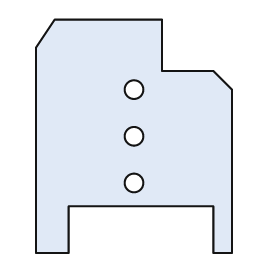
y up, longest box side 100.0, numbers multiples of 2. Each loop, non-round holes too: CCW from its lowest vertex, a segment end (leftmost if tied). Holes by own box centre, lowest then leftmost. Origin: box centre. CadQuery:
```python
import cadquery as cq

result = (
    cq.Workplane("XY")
    .moveTo(-42.0, -50.0)
    .lineTo(-28.0, -50.0)
    .lineTo(-28.0, -30.0)
    .lineTo(34.0, -30.0)
    .lineTo(34.0, -50.0)
    .lineTo(42.0, -50.0)
    .lineTo(42.0, 20.0)
    .lineTo(34.0, 28.0)
    .lineTo(12.0, 28.0)
    .lineTo(12.0, 50.0)
    .lineTo(-34.0, 50.0)
    .lineTo(-42.0, 38.0)
    .close()
    .moveTo(0.0, -20.0)
    .circle(4.0)
    .moveTo(0.0, 0.0)
    .circle(4.0)
    .moveTo(0.0, 20.0)
    .circle(4.0)
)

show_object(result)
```